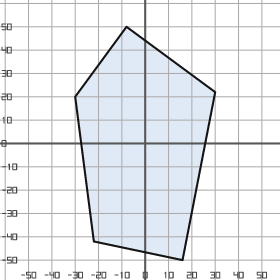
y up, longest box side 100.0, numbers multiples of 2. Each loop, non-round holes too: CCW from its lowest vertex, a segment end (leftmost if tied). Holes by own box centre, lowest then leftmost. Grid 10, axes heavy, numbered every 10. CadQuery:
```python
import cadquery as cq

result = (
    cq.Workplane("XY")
    .moveTo(16.0, -50.0)
    .lineTo(30.0, 22.0)
    .lineTo(-8.0, 50.0)
    .lineTo(-30.0, 20.0)
    .lineTo(-22.0, -42.0)
    .close()
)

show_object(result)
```